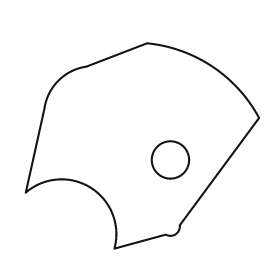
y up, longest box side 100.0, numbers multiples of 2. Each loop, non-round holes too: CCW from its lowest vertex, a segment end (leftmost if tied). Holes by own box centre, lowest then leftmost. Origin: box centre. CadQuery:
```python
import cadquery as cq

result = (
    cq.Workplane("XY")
    .moveTo(-12.0, -44.0)
    .lineTo(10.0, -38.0)
    .threePointArc((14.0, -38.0), (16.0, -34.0))
    .lineTo(50.0, 12.0)
    .threePointArc((30.0, 34.0), (2.0, 44.0))
    .lineTo(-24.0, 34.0)
    .threePointArc((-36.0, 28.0), (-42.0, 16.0))
    .lineTo(-50.0, -20.0)
    .threePointArc((-22.0, -18.0), (-12.0, -44.0))
    .close()
    .moveTo(12.0, -6.0)
    .circle(8.0)
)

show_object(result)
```